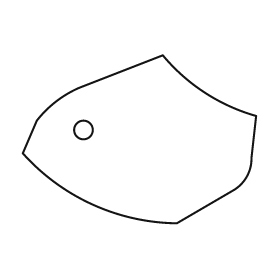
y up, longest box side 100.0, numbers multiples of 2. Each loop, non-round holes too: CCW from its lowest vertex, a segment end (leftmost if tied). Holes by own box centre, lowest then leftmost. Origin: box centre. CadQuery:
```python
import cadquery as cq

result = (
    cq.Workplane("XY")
    .moveTo(16.0, -36.0)
    .lineTo(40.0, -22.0)
    .threePointArc((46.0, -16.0), (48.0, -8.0))
    .lineTo(50.0, 10.0)
    .threePointArc((28.0, 20.0), (10.0, 36.0))
    .lineTo(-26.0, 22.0)
    .threePointArc((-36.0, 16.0), (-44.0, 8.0))
    .lineTo(-50.0, -6.0)
    .threePointArc((-20.0, -28.0), (16.0, -36.0))
    .close()
    .moveTo(-24.0, 4.0)
    .circle(4.0)
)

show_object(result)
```